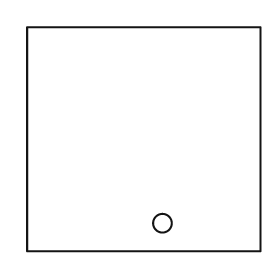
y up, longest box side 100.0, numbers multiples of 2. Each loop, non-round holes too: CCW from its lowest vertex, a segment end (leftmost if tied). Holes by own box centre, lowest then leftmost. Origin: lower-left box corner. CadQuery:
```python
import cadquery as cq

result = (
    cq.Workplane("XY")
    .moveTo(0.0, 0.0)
    .lineTo(100.0, 0.0)
    .lineTo(100.0, 96.0)
    .lineTo(0.0, 96.0)
    .close()
    .moveTo(58.0, 12.0)
    .circle(4.0)
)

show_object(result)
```